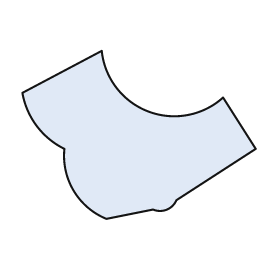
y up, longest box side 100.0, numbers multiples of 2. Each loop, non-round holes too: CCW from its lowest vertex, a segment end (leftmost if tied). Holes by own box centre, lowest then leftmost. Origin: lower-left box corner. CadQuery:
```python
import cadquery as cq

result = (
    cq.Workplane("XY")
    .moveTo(36.0, 0.0)
    .lineTo(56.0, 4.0)
    .threePointArc((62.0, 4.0), (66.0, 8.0))
    .lineTo(100.0, 30.0)
    .lineTo(86.0, 52.0)
    .threePointArc((54.0, 46.0), (34.0, 72.0))
    .lineTo(0.0, 54.0)
    .threePointArc((6.0, 40.0), (18.0, 30.0))
    .threePointArc((22.0, 12.0), (36.0, 0.0))
    .close()
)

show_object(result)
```